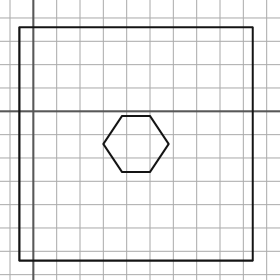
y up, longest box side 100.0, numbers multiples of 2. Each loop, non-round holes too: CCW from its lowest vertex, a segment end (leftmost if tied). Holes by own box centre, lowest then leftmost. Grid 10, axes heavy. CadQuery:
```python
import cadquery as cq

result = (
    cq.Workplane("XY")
    .moveTo(-6.0, -64.0)
    .lineTo(94.0, -64.0)
    .lineTo(94.0, 36.0)
    .lineTo(-6.0, 36.0)
    .close()
    .moveTo(38.0, -26.0)
    .lineTo(50.0, -26.0)
    .lineTo(58.0, -14.0)
    .lineTo(50.0, -2.0)
    .lineTo(38.0, -2.0)
    .lineTo(30.0, -14.0)
    .close()
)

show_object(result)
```